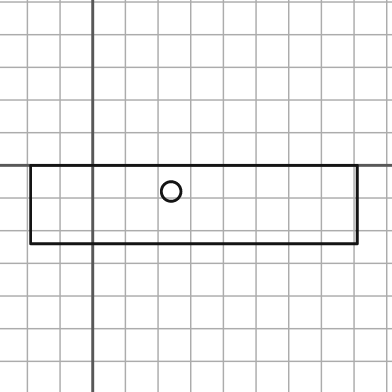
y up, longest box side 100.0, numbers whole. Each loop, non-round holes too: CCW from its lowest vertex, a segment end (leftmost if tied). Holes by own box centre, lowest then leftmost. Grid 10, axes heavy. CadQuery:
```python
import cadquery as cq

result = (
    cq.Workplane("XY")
    .moveTo(-19.0, -24.0)
    .lineTo(81.0, -24.0)
    .lineTo(81.0, 0.0)
    .lineTo(-19.0, 0.0)
    .close()
    .moveTo(24.0, -8.0)
    .circle(3.0)
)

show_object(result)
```